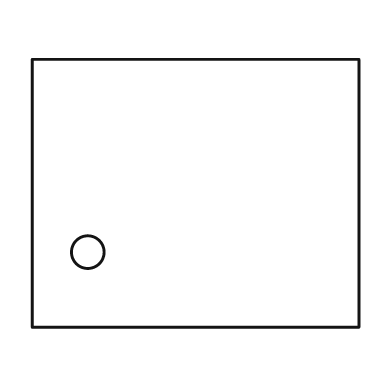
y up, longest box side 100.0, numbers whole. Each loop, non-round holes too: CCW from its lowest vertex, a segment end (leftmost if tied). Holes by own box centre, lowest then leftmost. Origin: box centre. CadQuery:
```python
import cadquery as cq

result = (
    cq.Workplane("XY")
    .moveTo(-50.0, -41.0)
    .lineTo(50.0, -41.0)
    .lineTo(50.0, 41.0)
    .lineTo(-50.0, 41.0)
    .close()
    .moveTo(-33.0, -18.0)
    .circle(5.0)
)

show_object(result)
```